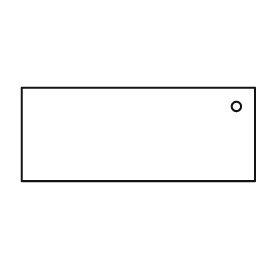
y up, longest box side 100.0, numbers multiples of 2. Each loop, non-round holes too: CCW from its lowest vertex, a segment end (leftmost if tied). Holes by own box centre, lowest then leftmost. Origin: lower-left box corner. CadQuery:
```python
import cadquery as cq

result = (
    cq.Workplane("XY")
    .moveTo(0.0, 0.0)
    .lineTo(100.0, 0.0)
    .lineTo(100.0, 40.0)
    .lineTo(0.0, 40.0)
    .close()
    .moveTo(92.0, 32.0)
    .circle(2.0)
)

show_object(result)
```